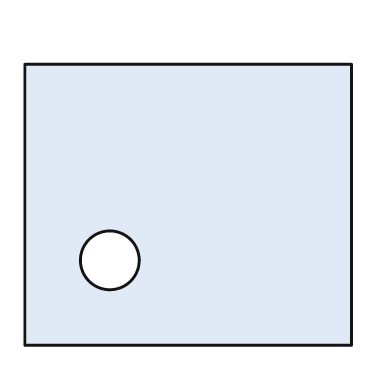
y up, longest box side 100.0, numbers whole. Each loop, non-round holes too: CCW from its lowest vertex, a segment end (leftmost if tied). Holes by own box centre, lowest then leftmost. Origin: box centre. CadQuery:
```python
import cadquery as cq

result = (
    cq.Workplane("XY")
    .moveTo(-50.0, -43.0)
    .lineTo(50.0, -43.0)
    .lineTo(50.0, 43.0)
    .lineTo(-50.0, 43.0)
    .close()
    .moveTo(-24.0, -17.0)
    .circle(9.0)
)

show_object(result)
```